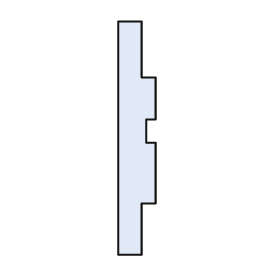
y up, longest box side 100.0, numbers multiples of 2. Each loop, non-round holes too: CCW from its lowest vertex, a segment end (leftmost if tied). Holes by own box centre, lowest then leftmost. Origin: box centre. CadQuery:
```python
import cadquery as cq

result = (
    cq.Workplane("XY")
    .moveTo(-8.0, -50.0)
    .lineTo(2.0, -50.0)
    .lineTo(2.0, -28.0)
    .lineTo(8.0, -28.0)
    .lineTo(8.0, -2.0)
    .lineTo(4.0, -2.0)
    .lineTo(4.0, 8.0)
    .lineTo(8.0, 8.0)
    .lineTo(8.0, 26.0)
    .lineTo(2.0, 26.0)
    .lineTo(2.0, 50.0)
    .lineTo(-8.0, 50.0)
    .close()
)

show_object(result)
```